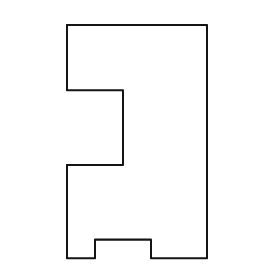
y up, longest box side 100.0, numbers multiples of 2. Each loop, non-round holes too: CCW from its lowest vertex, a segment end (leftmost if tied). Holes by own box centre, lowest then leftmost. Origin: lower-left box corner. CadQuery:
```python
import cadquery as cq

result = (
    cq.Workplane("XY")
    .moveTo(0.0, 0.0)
    .lineTo(12.0, 0.0)
    .lineTo(12.0, 8.0)
    .lineTo(36.0, 8.0)
    .lineTo(36.0, 0.0)
    .lineTo(60.0, 0.0)
    .lineTo(60.0, 100.0)
    .lineTo(0.0, 100.0)
    .lineTo(0.0, 72.0)
    .lineTo(24.0, 72.0)
    .lineTo(24.0, 40.0)
    .lineTo(0.0, 40.0)
    .close()
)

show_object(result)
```